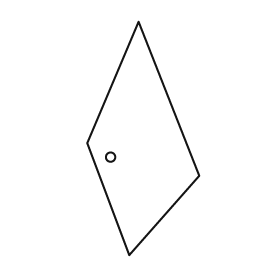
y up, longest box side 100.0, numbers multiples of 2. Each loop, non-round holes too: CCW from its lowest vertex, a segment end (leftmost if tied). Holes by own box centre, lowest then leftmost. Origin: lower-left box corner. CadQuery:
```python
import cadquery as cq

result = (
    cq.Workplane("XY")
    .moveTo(18.0, 0.0)
    .lineTo(48.0, 34.0)
    .lineTo(22.0, 100.0)
    .lineTo(0.0, 48.0)
    .close()
    .moveTo(10.0, 42.0)
    .circle(2.0)
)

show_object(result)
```